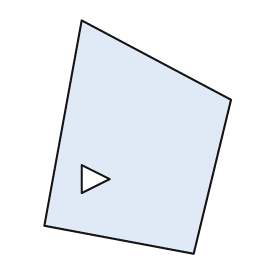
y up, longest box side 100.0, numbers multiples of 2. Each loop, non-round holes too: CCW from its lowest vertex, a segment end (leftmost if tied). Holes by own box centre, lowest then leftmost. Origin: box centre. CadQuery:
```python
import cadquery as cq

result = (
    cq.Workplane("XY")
    .moveTo(24.0, -50.0)
    .lineTo(40.0, 16.0)
    .lineTo(-24.0, 50.0)
    .lineTo(-40.0, -38.0)
    .close()
    .moveTo(-24.0, -24.0)
    .lineTo(-12.0, -18.0)
    .lineTo(-24.0, -12.0)
    .close()
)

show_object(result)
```